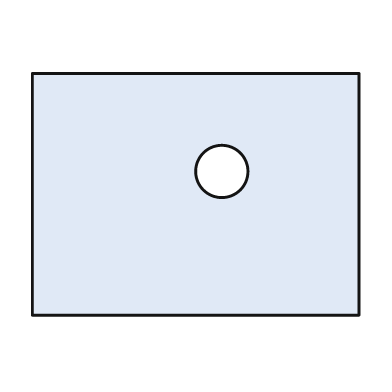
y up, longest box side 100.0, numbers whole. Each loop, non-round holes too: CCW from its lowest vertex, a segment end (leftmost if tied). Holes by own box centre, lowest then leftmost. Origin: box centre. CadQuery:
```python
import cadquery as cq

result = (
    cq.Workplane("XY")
    .moveTo(-50.0, -37.0)
    .lineTo(50.0, -37.0)
    .lineTo(50.0, 37.0)
    .lineTo(-50.0, 37.0)
    .close()
    .moveTo(8.0, 7.0)
    .circle(8.0)
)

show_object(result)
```